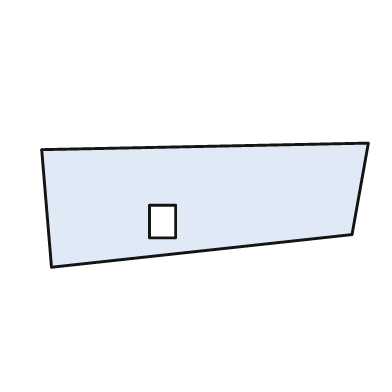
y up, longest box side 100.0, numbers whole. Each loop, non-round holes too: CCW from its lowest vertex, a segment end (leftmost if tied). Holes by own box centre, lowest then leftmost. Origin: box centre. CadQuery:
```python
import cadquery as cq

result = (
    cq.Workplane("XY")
    .moveTo(-47.0, -19.0)
    .lineTo(45.0, -9.0)
    .lineTo(50.0, 19.0)
    .lineTo(-50.0, 17.0)
    .close()
    .moveTo(-17.0, -10.0)
    .lineTo(-9.0, -10.0)
    .lineTo(-9.0, 0.0)
    .lineTo(-17.0, 0.0)
    .close()
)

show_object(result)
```